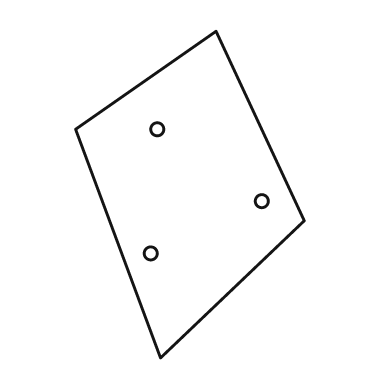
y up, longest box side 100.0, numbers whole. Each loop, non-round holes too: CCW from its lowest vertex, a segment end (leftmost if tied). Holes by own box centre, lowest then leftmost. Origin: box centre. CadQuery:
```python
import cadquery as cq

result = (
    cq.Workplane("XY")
    .moveTo(-9.0, -50.0)
    .lineTo(35.0, -8.0)
    .lineTo(8.0, 50.0)
    .lineTo(-35.0, 20.0)
    .close()
    .moveTo(-12.0, -18.0)
    .circle(2.0)
    .moveTo(22.0, -2.0)
    .circle(2.0)
    .moveTo(-10.0, 20.0)
    .circle(2.0)
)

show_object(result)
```